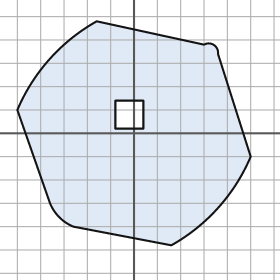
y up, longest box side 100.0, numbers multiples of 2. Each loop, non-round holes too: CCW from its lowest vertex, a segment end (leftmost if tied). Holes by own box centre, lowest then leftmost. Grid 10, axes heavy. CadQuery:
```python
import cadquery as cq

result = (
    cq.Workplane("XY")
    .moveTo(16.0, -48.0)
    .threePointArc((36.0, -32.0), (50.0, -10.0))
    .lineTo(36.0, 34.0)
    .threePointArc((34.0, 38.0), (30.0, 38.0))
    .lineTo(-16.0, 48.0)
    .threePointArc((-36.0, 32.0), (-50.0, 10.0))
    .lineTo(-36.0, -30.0)
    .threePointArc((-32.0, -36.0), (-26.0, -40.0))
    .close()
    .moveTo(-8.0, 2.0)
    .lineTo(4.0, 2.0)
    .lineTo(4.0, 14.0)
    .lineTo(-8.0, 14.0)
    .close()
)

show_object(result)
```